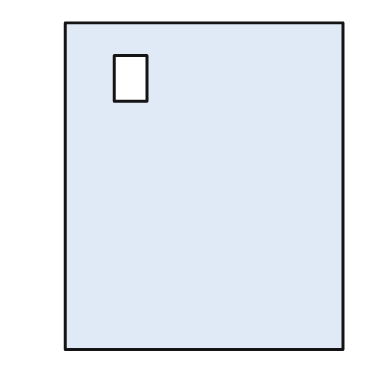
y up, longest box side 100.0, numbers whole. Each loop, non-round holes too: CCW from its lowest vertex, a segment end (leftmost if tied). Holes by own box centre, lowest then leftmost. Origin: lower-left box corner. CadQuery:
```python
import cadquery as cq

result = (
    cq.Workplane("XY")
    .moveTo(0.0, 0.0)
    .lineTo(85.0, 0.0)
    .lineTo(85.0, 100.0)
    .lineTo(0.0, 100.0)
    .close()
    .moveTo(15.0, 76.0)
    .lineTo(25.0, 76.0)
    .lineTo(25.0, 90.0)
    .lineTo(15.0, 90.0)
    .close()
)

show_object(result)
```